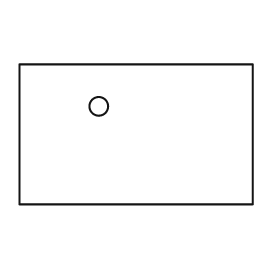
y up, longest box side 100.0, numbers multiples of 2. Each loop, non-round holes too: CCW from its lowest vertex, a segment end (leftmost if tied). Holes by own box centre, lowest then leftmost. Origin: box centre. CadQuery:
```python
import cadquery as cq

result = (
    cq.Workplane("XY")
    .moveTo(-50.0, -30.0)
    .lineTo(50.0, -30.0)
    .lineTo(50.0, 30.0)
    .lineTo(-50.0, 30.0)
    .close()
    .moveTo(-16.0, 12.0)
    .circle(4.0)
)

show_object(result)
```